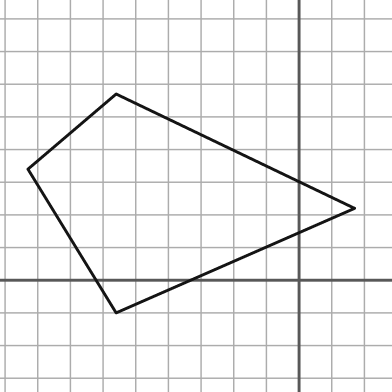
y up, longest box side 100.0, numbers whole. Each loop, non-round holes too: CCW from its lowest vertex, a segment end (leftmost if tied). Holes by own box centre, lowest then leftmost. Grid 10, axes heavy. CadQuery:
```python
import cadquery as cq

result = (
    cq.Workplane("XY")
    .moveTo(-56.0, -10.0)
    .lineTo(17.0, 22.0)
    .lineTo(-56.0, 57.0)
    .lineTo(-83.0, 34.0)
    .close()
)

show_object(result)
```